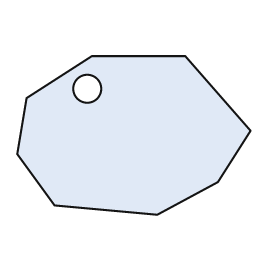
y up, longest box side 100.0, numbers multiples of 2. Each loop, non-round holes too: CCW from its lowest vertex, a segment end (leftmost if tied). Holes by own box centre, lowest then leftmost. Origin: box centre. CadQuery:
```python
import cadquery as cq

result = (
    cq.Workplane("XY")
    .moveTo(10.0, -34.0)
    .lineTo(36.0, -20.0)
    .lineTo(50.0, 2.0)
    .lineTo(22.0, 34.0)
    .lineTo(-18.0, 34.0)
    .lineTo(-46.0, 16.0)
    .lineTo(-50.0, -8.0)
    .lineTo(-34.0, -30.0)
    .close()
    .moveTo(-20.0, 20.0)
    .circle(6.0)
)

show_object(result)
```